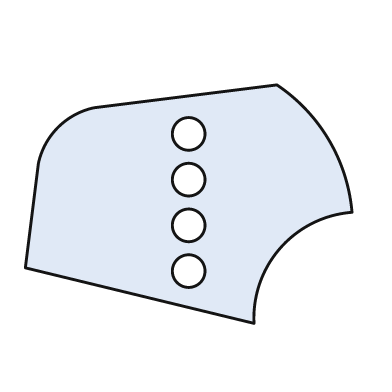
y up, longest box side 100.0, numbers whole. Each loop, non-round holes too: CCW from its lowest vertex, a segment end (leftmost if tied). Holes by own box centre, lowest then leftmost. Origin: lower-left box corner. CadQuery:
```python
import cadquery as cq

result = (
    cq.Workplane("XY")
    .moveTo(70.0, 0.0)
    .threePointArc((78.0, 23.0), (100.0, 34.0))
    .threePointArc((93.0, 56.0), (77.0, 73.0))
    .lineTo(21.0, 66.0)
    .threePointArc((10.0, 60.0), (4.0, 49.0))
    .lineTo(0.0, 17.0)
    .close()
    .moveTo(50.0, 16.0)
    .circle(5.0)
    .moveTo(50.0, 30.0)
    .circle(5.0)
    .moveTo(50.0, 44.0)
    .circle(5.0)
    .moveTo(50.0, 58.0)
    .circle(5.0)
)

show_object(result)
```